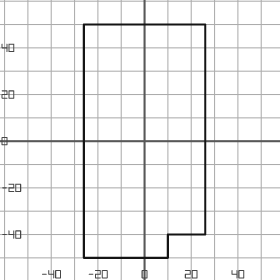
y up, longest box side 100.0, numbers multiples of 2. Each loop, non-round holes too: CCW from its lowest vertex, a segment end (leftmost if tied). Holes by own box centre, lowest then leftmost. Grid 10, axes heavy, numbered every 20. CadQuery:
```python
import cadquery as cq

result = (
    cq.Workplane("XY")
    .moveTo(-26.0, -50.0)
    .lineTo(10.0, -50.0)
    .lineTo(10.0, -40.0)
    .lineTo(26.0, -40.0)
    .lineTo(26.0, 50.0)
    .lineTo(-26.0, 50.0)
    .close()
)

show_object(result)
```